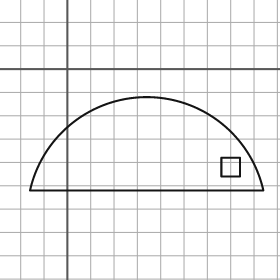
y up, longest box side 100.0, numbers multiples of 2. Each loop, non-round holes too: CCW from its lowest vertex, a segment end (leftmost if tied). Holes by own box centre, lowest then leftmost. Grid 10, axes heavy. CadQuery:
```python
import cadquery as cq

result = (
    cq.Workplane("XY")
    .moveTo(-16.0, -52.0)
    .lineTo(84.0, -52.0)
    .threePointArc((34.0, -12.0), (-16.0, -52.0))
    .close()
    .moveTo(66.0, -46.0)
    .lineTo(74.0, -46.0)
    .lineTo(74.0, -38.0)
    .lineTo(66.0, -38.0)
    .close()
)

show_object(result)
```